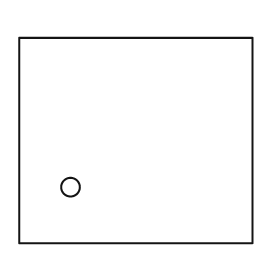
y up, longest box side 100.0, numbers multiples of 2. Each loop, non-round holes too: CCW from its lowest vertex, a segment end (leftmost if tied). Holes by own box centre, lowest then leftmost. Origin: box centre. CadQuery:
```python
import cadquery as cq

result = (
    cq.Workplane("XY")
    .moveTo(-50.0, -44.0)
    .lineTo(50.0, -44.0)
    .lineTo(50.0, 44.0)
    .lineTo(-50.0, 44.0)
    .close()
    .moveTo(-28.0, -20.0)
    .circle(4.0)
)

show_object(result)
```